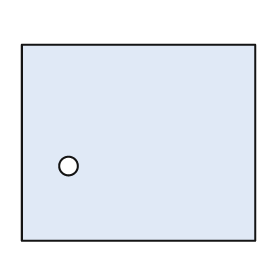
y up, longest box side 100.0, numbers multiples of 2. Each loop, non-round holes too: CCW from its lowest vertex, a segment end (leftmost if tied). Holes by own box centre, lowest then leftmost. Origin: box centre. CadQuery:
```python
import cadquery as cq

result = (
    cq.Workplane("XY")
    .moveTo(-50.0, -42.0)
    .lineTo(50.0, -42.0)
    .lineTo(50.0, 42.0)
    .lineTo(-50.0, 42.0)
    .close()
    .moveTo(-30.0, -10.0)
    .circle(4.0)
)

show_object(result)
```